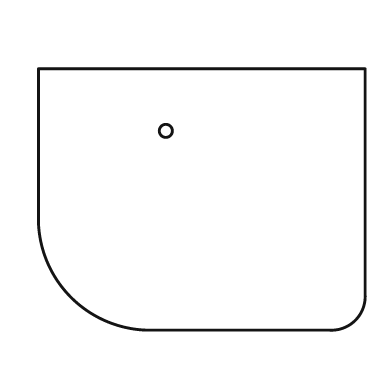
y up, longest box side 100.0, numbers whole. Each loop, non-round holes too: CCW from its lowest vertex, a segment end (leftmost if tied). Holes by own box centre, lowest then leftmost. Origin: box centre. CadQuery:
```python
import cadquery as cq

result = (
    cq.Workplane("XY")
    .moveTo(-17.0, -40.0)
    .lineTo(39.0, -40.0)
    .threePointArc((47.0, -37.0), (50.0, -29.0))
    .lineTo(50.0, 40.0)
    .lineTo(-50.0, 40.0)
    .lineTo(-50.0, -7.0)
    .threePointArc((-40.0, -30.0), (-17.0, -40.0))
    .close()
    .moveTo(-11.0, 21.0)
    .circle(2.0)
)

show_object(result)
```